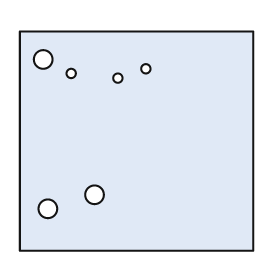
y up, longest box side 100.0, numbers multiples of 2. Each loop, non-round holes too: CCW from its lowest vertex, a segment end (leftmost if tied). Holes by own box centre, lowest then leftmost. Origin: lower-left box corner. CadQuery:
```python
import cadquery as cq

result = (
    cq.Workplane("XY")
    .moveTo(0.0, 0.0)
    .lineTo(100.0, 0.0)
    .lineTo(100.0, 94.0)
    .lineTo(0.0, 94.0)
    .close()
    .moveTo(12.0, 18.0)
    .circle(4.0)
    .moveTo(32.0, 24.0)
    .circle(4.0)
    .moveTo(42.0, 74.0)
    .circle(2.0)
    .moveTo(22.0, 76.0)
    .circle(2.0)
    .moveTo(54.0, 78.0)
    .circle(2.0)
    .moveTo(10.0, 82.0)
    .circle(4.0)
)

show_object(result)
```